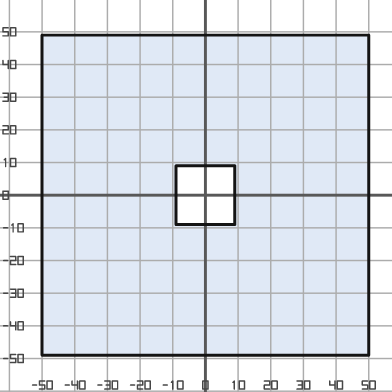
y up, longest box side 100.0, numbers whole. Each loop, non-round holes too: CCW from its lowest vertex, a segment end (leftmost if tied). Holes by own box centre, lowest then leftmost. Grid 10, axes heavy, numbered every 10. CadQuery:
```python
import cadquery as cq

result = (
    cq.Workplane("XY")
    .moveTo(-50.0, -49.0)
    .lineTo(50.0, -49.0)
    .lineTo(50.0, 49.0)
    .lineTo(-50.0, 49.0)
    .close()
    .moveTo(-9.0, -9.0)
    .lineTo(9.0, -9.0)
    .lineTo(9.0, 9.0)
    .lineTo(-9.0, 9.0)
    .close()
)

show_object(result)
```